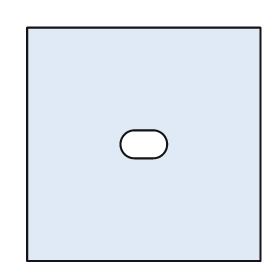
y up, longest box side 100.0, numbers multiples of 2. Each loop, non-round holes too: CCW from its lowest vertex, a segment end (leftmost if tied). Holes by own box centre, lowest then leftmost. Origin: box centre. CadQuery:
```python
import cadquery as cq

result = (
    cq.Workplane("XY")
    .moveTo(-50.0, -50.0)
    .lineTo(50.0, -50.0)
    .lineTo(50.0, 50.0)
    .lineTo(-50.0, 50.0)
    .close()
    .moveTo(-4.0, -6.0)
    .lineTo(4.0, -6.0)
    .threePointArc((10.0, 0.0), (4.0, 6.0))
    .lineTo(-4.0, 6.0)
    .threePointArc((-10.0, 0.0), (-4.0, -6.0))
    .close()
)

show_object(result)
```